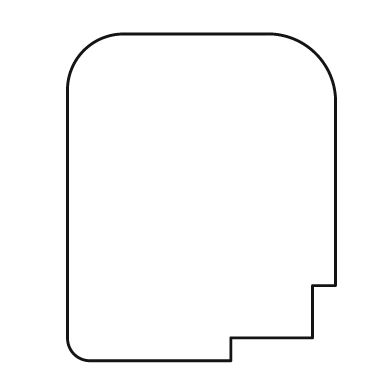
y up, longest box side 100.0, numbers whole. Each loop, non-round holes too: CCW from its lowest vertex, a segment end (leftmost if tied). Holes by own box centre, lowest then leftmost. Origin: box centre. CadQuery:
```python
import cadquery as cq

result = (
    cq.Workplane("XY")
    .moveTo(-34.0, -50.0)
    .lineTo(9.0, -50.0)
    .lineTo(9.0, -43.0)
    .lineTo(34.0, -43.0)
    .lineTo(34.0, -27.0)
    .lineTo(41.0, -27.0)
    .lineTo(41.0, 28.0)
    .threePointArc((35.0, 44.0), (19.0, 50.0))
    .lineTo(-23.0, 50.0)
    .threePointArc((-36.0, 45.0), (-41.0, 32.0))
    .lineTo(-41.0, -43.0)
    .threePointArc((-39.0, -48.0), (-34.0, -50.0))
    .close()
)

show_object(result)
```